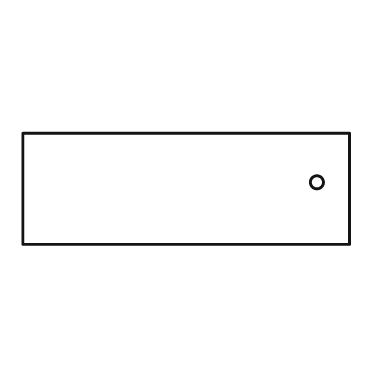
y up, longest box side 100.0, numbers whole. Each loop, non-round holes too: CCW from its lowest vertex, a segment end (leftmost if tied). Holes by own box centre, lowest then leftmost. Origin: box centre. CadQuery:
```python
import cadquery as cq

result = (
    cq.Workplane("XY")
    .moveTo(-50.0, -17.0)
    .lineTo(50.0, -17.0)
    .lineTo(50.0, 17.0)
    .lineTo(-50.0, 17.0)
    .close()
    .moveTo(40.0, 2.0)
    .circle(2.0)
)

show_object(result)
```